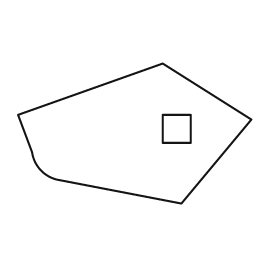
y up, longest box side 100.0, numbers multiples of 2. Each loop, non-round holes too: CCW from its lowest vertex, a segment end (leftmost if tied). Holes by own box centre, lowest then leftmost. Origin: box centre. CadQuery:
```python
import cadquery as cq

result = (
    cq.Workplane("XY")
    .moveTo(20.0, -30.0)
    .lineTo(50.0, 6.0)
    .lineTo(12.0, 30.0)
    .lineTo(-50.0, 8.0)
    .lineTo(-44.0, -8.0)
    .threePointArc((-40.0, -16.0), (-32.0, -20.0))
    .close()
    .moveTo(12.0, -4.0)
    .lineTo(24.0, -4.0)
    .lineTo(24.0, 8.0)
    .lineTo(12.0, 8.0)
    .close()
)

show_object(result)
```